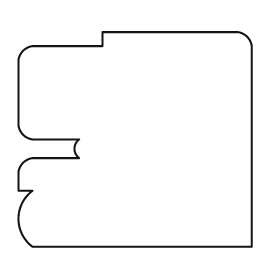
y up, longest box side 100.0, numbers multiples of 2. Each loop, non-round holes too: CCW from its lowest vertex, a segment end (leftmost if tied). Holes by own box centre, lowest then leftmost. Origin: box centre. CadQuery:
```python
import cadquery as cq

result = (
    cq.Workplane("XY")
    .moveTo(-44.0, -46.0)
    .lineTo(50.0, -46.0)
    .lineTo(50.0, 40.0)
    .threePointArc((48.0, 44.0), (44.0, 46.0))
    .lineTo(-14.0, 46.0)
    .lineTo(-14.0, 40.0)
    .lineTo(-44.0, 40.0)
    .threePointArc((-48.0, 38.0), (-50.0, 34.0))
    .lineTo(-50.0, 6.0)
    .threePointArc((-48.0, 2.0), (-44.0, 0.0))
    .lineTo(-24.0, 0.0)
    .threePointArc((-26.0, -4.0), (-24.0, -8.0))
    .lineTo(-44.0, -8.0)
    .threePointArc((-48.0, -10.0), (-50.0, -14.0))
    .lineTo(-50.0, -22.0)
    .lineTo(-44.0, -22.0)
    .threePointArc((-50.0, -34.0), (-44.0, -46.0))
    .close()
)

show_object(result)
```